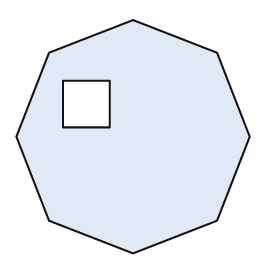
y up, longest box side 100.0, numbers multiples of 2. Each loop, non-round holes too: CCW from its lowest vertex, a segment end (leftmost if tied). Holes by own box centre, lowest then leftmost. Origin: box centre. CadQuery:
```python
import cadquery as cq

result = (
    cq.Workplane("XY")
    .moveTo(0.0, -50.0)
    .lineTo(36.0, -36.0)
    .lineTo(50.0, 0.0)
    .lineTo(36.0, 36.0)
    .lineTo(0.0, 50.0)
    .lineTo(-36.0, 36.0)
    .lineTo(-50.0, 0.0)
    .lineTo(-36.0, -36.0)
    .close()
    .moveTo(-30.0, 4.0)
    .lineTo(-10.0, 4.0)
    .lineTo(-10.0, 24.0)
    .lineTo(-30.0, 24.0)
    .close()
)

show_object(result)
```